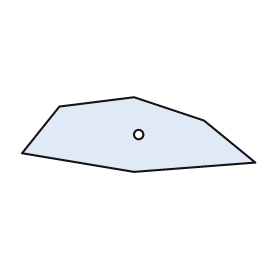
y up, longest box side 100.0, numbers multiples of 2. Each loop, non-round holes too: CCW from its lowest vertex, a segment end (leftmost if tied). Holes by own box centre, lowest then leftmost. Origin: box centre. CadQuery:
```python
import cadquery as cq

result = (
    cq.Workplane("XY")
    .moveTo(-2.0, -16.0)
    .lineTo(50.0, -12.0)
    .lineTo(28.0, 6.0)
    .lineTo(-2.0, 16.0)
    .lineTo(-34.0, 12.0)
    .lineTo(-50.0, -8.0)
    .close()
    .moveTo(0.0, 0.0)
    .circle(2.0)
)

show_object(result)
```